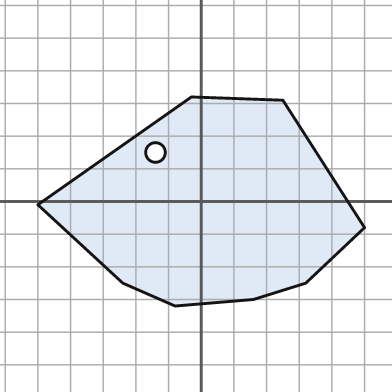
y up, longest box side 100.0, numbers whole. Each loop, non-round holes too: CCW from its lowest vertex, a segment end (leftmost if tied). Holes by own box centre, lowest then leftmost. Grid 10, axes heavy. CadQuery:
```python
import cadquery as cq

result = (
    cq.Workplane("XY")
    .moveTo(-8.0, -32.0)
    .lineTo(16.0, -30.0)
    .lineTo(32.0, -25.0)
    .lineTo(50.0, -8.0)
    .lineTo(25.0, 31.0)
    .lineTo(-3.0, 32.0)
    .lineTo(-50.0, -1.0)
    .lineTo(-24.0, -25.0)
    .close()
    .moveTo(-14.0, 15.0)
    .circle(3.0)
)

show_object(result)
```